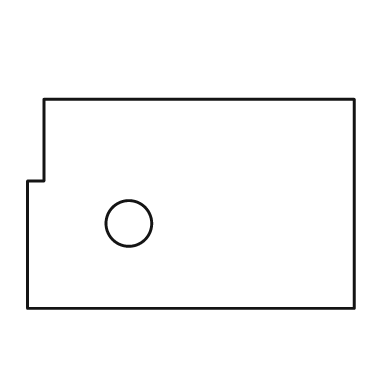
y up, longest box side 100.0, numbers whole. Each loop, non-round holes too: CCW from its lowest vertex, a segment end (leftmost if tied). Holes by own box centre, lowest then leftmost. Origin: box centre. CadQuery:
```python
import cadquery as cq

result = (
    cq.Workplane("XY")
    .moveTo(-50.0, -32.0)
    .lineTo(50.0, -32.0)
    .lineTo(50.0, 32.0)
    .lineTo(-45.0, 32.0)
    .lineTo(-45.0, 7.0)
    .lineTo(-50.0, 7.0)
    .close()
    .moveTo(-19.0, -6.0)
    .circle(7.0)
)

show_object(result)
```